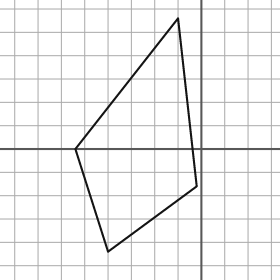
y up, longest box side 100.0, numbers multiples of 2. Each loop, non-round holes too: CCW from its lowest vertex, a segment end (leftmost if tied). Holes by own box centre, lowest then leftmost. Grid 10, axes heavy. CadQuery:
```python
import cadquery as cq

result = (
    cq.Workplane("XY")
    .moveTo(-40.0, -44.0)
    .lineTo(-2.0, -16.0)
    .lineTo(-10.0, 56.0)
    .lineTo(-54.0, 0.0)
    .close()
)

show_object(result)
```